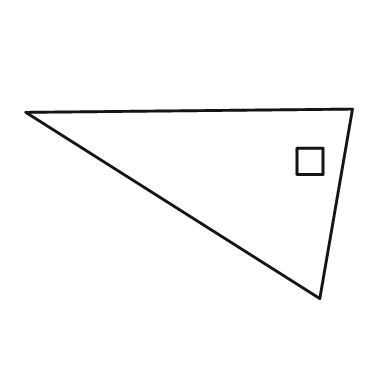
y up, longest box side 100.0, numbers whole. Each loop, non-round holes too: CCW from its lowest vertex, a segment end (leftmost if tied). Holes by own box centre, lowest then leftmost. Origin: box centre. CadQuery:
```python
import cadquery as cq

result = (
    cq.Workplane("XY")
    .moveTo(40.0, -29.0)
    .lineTo(50.0, 29.0)
    .lineTo(-50.0, 28.0)
    .close()
    .moveTo(33.0, 9.0)
    .lineTo(41.0, 9.0)
    .lineTo(41.0, 17.0)
    .lineTo(33.0, 17.0)
    .close()
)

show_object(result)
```